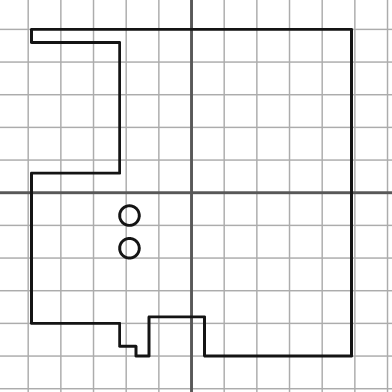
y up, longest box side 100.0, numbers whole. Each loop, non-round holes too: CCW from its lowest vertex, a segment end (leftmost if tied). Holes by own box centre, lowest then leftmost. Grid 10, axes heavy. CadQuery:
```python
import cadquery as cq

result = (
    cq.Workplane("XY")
    .moveTo(-17.0, -50.0)
    .lineTo(-13.0, -50.0)
    .lineTo(-13.0, -38.0)
    .lineTo(4.0, -38.0)
    .lineTo(4.0, -50.0)
    .lineTo(49.0, -50.0)
    .lineTo(49.0, 50.0)
    .lineTo(-49.0, 50.0)
    .lineTo(-49.0, 46.0)
    .lineTo(-22.0, 46.0)
    .lineTo(-22.0, 6.0)
    .lineTo(-49.0, 6.0)
    .lineTo(-49.0, -40.0)
    .lineTo(-22.0, -40.0)
    .lineTo(-22.0, -47.0)
    .lineTo(-17.0, -47.0)
    .close()
    .moveTo(-19.0, -17.0)
    .circle(3.0)
    .moveTo(-19.0, -7.0)
    .circle(3.0)
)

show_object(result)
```